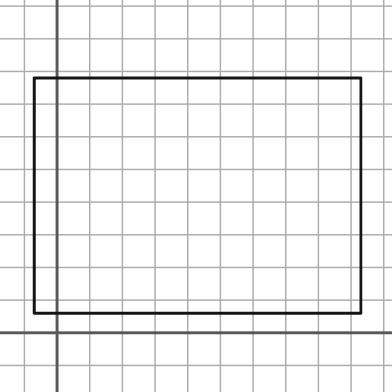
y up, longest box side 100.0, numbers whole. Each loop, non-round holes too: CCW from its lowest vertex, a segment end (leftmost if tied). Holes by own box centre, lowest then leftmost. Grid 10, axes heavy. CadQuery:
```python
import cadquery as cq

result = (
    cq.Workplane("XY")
    .moveTo(-7.0, 6.0)
    .lineTo(93.0, 6.0)
    .lineTo(93.0, 78.0)
    .lineTo(-7.0, 78.0)
    .close()
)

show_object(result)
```